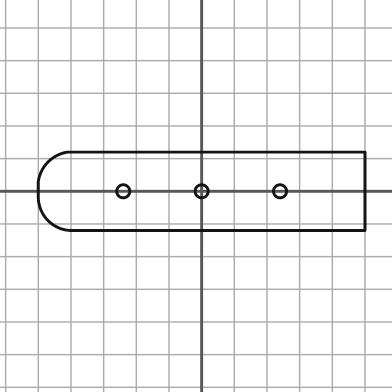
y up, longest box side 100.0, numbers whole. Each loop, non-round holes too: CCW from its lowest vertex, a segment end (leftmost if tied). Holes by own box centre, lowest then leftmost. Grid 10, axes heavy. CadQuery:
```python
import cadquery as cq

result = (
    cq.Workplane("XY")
    .moveTo(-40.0, -12.0)
    .lineTo(50.0, -12.0)
    .lineTo(50.0, 12.0)
    .lineTo(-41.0, 12.0)
    .threePointArc((-47.0, 9.0), (-50.0, 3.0))
    .lineTo(-50.0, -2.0)
    .threePointArc((-47.0, -9.0), (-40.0, -12.0))
    .close()
    .moveTo(-24.0, 0.0)
    .circle(2.0)
    .moveTo(0.0, 0.0)
    .circle(2.0)
    .moveTo(24.0, 0.0)
    .circle(2.0)
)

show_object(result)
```